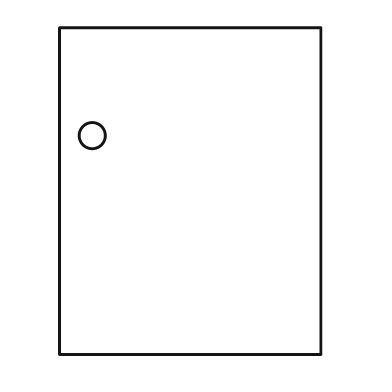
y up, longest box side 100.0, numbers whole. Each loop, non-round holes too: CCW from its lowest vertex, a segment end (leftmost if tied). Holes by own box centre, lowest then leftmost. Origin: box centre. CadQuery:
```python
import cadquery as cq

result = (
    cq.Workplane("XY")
    .moveTo(-40.0, -50.0)
    .lineTo(40.0, -50.0)
    .lineTo(40.0, 50.0)
    .lineTo(-40.0, 50.0)
    .close()
    .moveTo(-30.0, 17.0)
    .circle(4.0)
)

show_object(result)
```